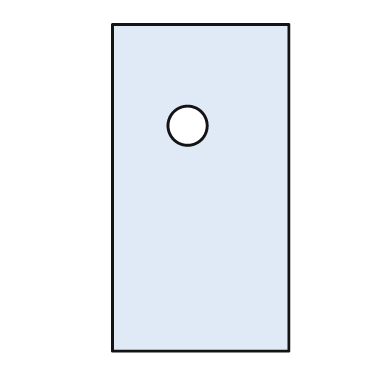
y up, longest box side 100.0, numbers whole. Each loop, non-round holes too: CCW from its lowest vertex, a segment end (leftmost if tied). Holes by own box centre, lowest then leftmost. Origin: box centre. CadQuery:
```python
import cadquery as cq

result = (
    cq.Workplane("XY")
    .moveTo(-27.0, -50.0)
    .lineTo(27.0, -50.0)
    .lineTo(27.0, 50.0)
    .lineTo(-27.0, 50.0)
    .close()
    .moveTo(-4.0, 19.0)
    .circle(6.0)
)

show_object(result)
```